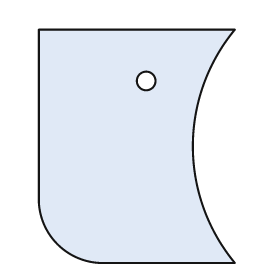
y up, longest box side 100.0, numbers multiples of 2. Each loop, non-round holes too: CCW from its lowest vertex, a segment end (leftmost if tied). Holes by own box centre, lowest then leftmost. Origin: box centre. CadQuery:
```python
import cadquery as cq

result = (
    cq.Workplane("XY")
    .moveTo(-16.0, -50.0)
    .lineTo(42.0, -50.0)
    .threePointArc((24.0, 0.0), (42.0, 50.0))
    .lineTo(-42.0, 50.0)
    .lineTo(-42.0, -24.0)
    .threePointArc((-34.0, -42.0), (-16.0, -50.0))
    .close()
    .moveTo(4.0, 28.0)
    .circle(4.0)
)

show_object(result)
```